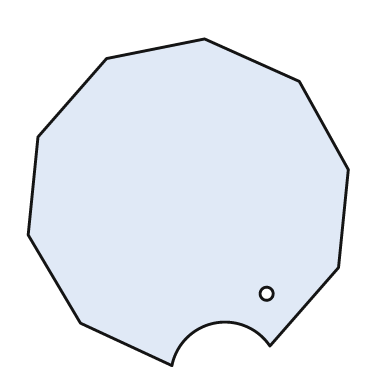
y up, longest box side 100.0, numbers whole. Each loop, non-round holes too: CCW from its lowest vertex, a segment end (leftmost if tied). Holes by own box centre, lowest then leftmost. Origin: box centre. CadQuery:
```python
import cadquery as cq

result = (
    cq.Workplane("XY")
    .moveTo(-5.0, -50.0)
    .threePointArc((8.0, -37.0), (25.0, -44.0))
    .lineTo(46.0, -20.0)
    .lineTo(49.0, 10.0)
    .lineTo(34.0, 37.0)
    .lineTo(5.0, 50.0)
    .lineTo(-25.0, 44.0)
    .lineTo(-46.0, 20.0)
    .lineTo(-49.0, -10.0)
    .lineTo(-33.0, -37.0)
    .close()
    .moveTo(24.0, -28.0)
    .circle(2.0)
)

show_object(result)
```